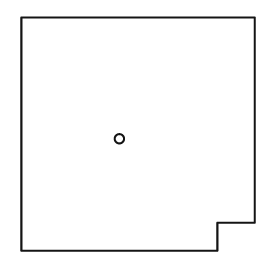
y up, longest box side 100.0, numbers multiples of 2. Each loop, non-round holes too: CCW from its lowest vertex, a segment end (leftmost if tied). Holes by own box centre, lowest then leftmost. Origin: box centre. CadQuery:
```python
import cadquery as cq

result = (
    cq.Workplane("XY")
    .moveTo(-50.0, -50.0)
    .lineTo(34.0, -50.0)
    .lineTo(34.0, -38.0)
    .lineTo(50.0, -38.0)
    .lineTo(50.0, 50.0)
    .lineTo(-50.0, 50.0)
    .close()
    .moveTo(-8.0, -2.0)
    .circle(2.0)
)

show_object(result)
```